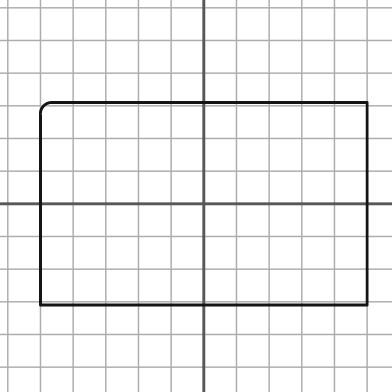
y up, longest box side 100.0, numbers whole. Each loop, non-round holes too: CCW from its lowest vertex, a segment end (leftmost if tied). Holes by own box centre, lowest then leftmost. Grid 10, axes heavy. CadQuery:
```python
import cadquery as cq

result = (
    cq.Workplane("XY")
    .moveTo(-50.0, -31.0)
    .lineTo(50.0, -31.0)
    .lineTo(50.0, 31.0)
    .lineTo(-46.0, 31.0)
    .threePointArc((-49.0, 30.0), (-50.0, 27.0))
    .close()
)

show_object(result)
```